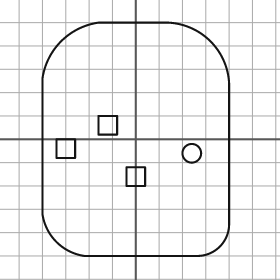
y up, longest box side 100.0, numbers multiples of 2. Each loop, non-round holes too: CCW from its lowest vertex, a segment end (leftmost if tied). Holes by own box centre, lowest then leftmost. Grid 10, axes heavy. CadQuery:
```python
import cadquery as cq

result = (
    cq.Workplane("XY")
    .moveTo(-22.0, -50.0)
    .lineTo(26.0, -50.0)
    .threePointArc((36.0, -46.0), (40.0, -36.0))
    .lineTo(40.0, 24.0)
    .threePointArc((32.0, 42.0), (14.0, 50.0))
    .lineTo(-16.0, 50.0)
    .threePointArc((-32.0, 42.0), (-40.0, 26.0))
    .lineTo(-40.0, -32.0)
    .threePointArc((-34.0, -44.0), (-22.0, -50.0))
    .close()
    .moveTo(-4.0, -20.0)
    .lineTo(4.0, -20.0)
    .lineTo(4.0, -12.0)
    .lineTo(-4.0, -12.0)
    .close()
    .moveTo(24.0, -6.0)
    .circle(4.0)
    .moveTo(-34.0, -8.0)
    .lineTo(-26.0, -8.0)
    .lineTo(-26.0, 0.0)
    .lineTo(-34.0, 0.0)
    .close()
    .moveTo(-16.0, 2.0)
    .lineTo(-8.0, 2.0)
    .lineTo(-8.0, 10.0)
    .lineTo(-16.0, 10.0)
    .close()
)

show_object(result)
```